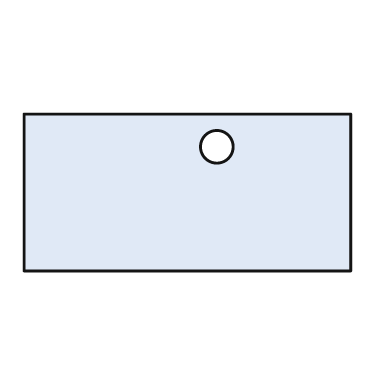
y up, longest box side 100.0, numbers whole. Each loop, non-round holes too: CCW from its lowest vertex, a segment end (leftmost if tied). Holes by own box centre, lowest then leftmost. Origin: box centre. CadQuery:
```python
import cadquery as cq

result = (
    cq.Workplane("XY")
    .moveTo(-50.0, -24.0)
    .lineTo(50.0, -24.0)
    .lineTo(50.0, 24.0)
    .lineTo(-50.0, 24.0)
    .close()
    .moveTo(9.0, 14.0)
    .circle(5.0)
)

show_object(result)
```